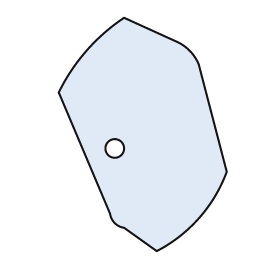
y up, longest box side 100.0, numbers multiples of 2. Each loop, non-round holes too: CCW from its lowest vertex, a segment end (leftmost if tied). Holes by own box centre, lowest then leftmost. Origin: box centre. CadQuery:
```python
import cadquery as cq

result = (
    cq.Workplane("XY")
    .moveTo(6.0, -50.0)
    .threePointArc((24.0, -36.0), (36.0, -16.0))
    .lineTo(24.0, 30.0)
    .threePointArc((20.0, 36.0), (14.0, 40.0))
    .lineTo(-8.0, 50.0)
    .threePointArc((-24.0, 36.0), (-36.0, 18.0))
    .lineTo(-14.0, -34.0)
    .threePointArc((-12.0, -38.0), (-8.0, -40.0))
    .close()
    .moveTo(-12.0, -6.0)
    .circle(4.0)
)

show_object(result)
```